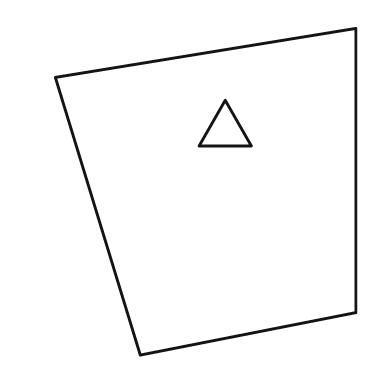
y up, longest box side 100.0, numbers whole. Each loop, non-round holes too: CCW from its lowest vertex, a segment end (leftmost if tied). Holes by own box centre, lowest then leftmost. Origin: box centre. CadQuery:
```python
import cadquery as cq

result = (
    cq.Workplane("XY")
    .moveTo(-20.0, -50.0)
    .lineTo(46.0, -37.0)
    .lineTo(46.0, 50.0)
    .lineTo(-46.0, 35.0)
    .close()
    .moveTo(-2.0, 14.0)
    .lineTo(14.0, 14.0)
    .lineTo(6.0, 28.0)
    .close()
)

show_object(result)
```